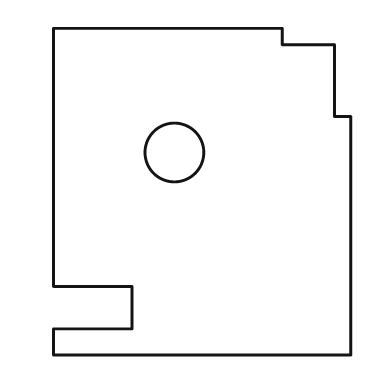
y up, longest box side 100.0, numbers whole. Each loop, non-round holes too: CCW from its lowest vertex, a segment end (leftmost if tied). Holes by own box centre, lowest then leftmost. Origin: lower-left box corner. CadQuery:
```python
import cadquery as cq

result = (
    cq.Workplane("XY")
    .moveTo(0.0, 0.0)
    .lineTo(91.0, 0.0)
    .lineTo(91.0, 73.0)
    .lineTo(86.0, 73.0)
    .lineTo(86.0, 95.0)
    .lineTo(70.0, 95.0)
    .lineTo(70.0, 100.0)
    .lineTo(0.0, 100.0)
    .lineTo(0.0, 21.0)
    .lineTo(24.0, 21.0)
    .lineTo(24.0, 8.0)
    .lineTo(0.0, 8.0)
    .close()
    .moveTo(37.0, 62.0)
    .circle(9.0)
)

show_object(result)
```